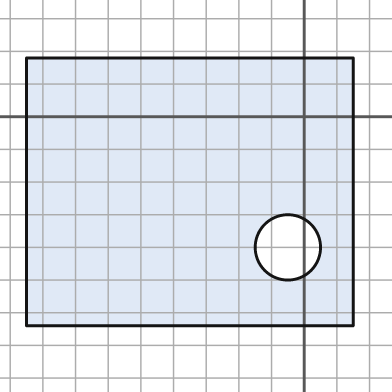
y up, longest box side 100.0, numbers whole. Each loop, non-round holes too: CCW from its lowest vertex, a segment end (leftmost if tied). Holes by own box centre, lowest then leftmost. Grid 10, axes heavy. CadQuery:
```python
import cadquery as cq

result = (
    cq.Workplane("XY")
    .moveTo(-85.0, -64.0)
    .lineTo(15.0, -64.0)
    .lineTo(15.0, 18.0)
    .lineTo(-85.0, 18.0)
    .close()
    .moveTo(-5.0, -40.0)
    .circle(10.0)
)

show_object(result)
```